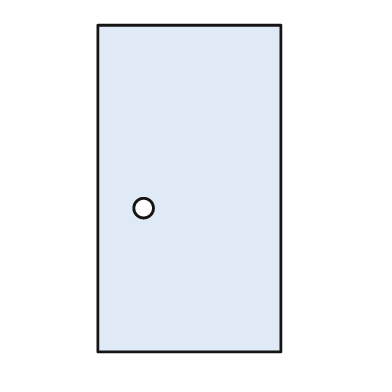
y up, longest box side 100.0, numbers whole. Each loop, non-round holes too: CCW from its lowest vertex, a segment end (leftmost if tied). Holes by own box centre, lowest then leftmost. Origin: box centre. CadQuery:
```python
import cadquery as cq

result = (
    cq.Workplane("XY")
    .moveTo(-28.0, -50.0)
    .lineTo(28.0, -50.0)
    .lineTo(28.0, 50.0)
    .lineTo(-28.0, 50.0)
    .close()
    .moveTo(-14.0, -6.0)
    .circle(3.0)
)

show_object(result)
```